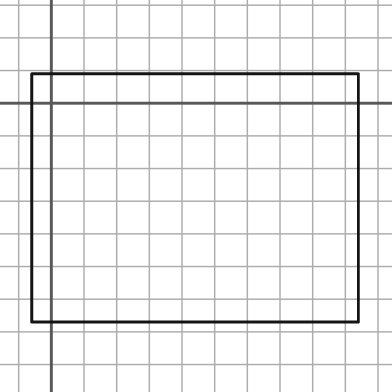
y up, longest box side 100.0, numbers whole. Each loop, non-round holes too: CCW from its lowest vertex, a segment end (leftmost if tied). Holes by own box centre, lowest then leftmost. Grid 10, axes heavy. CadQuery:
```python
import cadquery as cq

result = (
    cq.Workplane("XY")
    .moveTo(-6.0, -67.0)
    .lineTo(94.0, -67.0)
    .lineTo(94.0, 9.0)
    .lineTo(-6.0, 9.0)
    .close()
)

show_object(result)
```